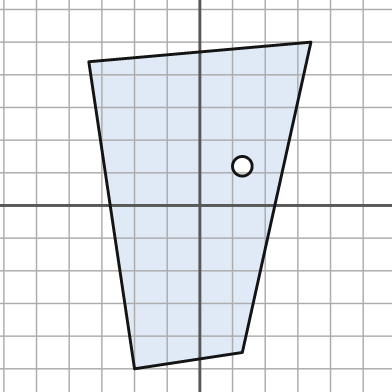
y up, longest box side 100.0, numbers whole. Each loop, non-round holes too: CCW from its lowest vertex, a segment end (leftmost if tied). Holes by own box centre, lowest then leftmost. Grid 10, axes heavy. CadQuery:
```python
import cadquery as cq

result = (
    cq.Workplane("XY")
    .moveTo(-20.0, -50.0)
    .lineTo(13.0, -45.0)
    .lineTo(34.0, 50.0)
    .lineTo(-34.0, 44.0)
    .close()
    .moveTo(13.0, 12.0)
    .circle(3.0)
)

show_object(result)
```